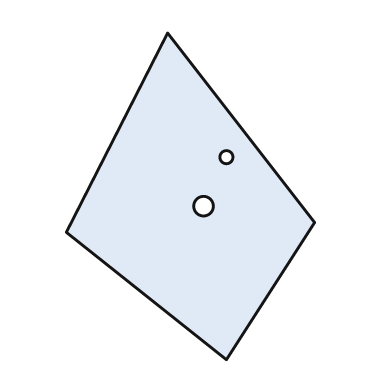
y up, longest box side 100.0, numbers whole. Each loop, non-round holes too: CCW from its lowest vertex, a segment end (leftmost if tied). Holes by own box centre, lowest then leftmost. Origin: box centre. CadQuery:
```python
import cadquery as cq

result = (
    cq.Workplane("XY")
    .moveTo(11.0, -50.0)
    .lineTo(38.0, -8.0)
    .lineTo(-7.0, 50.0)
    .lineTo(-38.0, -11.0)
    .close()
    .moveTo(4.0, -3.0)
    .circle(3.0)
    .moveTo(11.0, 12.0)
    .circle(2.0)
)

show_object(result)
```